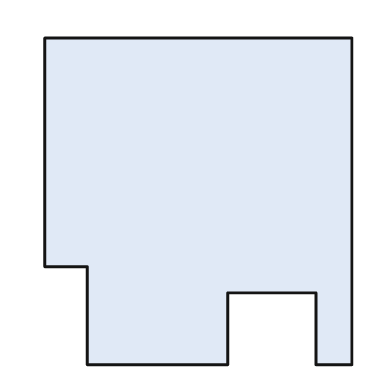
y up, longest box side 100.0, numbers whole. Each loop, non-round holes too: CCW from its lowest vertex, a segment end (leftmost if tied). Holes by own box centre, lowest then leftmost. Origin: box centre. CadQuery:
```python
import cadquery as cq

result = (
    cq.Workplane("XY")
    .moveTo(-34.0, -50.0)
    .lineTo(9.0, -50.0)
    .lineTo(9.0, -28.0)
    .lineTo(36.0, -28.0)
    .lineTo(36.0, -50.0)
    .lineTo(47.0, -50.0)
    .lineTo(47.0, 50.0)
    .lineTo(-47.0, 50.0)
    .lineTo(-47.0, -20.0)
    .lineTo(-34.0, -20.0)
    .close()
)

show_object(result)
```